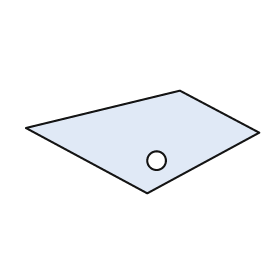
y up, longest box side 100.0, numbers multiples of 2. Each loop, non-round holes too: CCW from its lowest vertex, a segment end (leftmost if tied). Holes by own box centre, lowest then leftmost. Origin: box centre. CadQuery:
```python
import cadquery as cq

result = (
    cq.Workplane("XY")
    .moveTo(2.0, -22.0)
    .lineTo(50.0, 4.0)
    .lineTo(16.0, 22.0)
    .lineTo(-50.0, 6.0)
    .close()
    .moveTo(6.0, -8.0)
    .circle(4.0)
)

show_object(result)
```